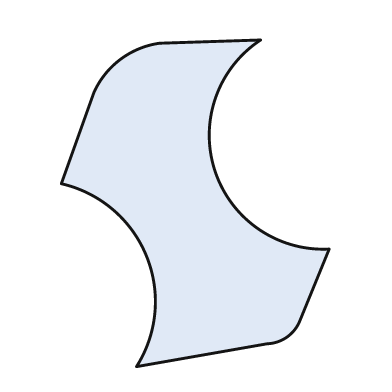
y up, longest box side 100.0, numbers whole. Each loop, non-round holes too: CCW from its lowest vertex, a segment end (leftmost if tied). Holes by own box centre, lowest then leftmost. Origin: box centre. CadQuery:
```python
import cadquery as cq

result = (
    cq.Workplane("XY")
    .moveTo(-18.0, -50.0)
    .lineTo(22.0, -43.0)
    .threePointArc((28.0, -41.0), (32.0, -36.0))
    .lineTo(41.0, -14.0)
    .threePointArc((6.0, 10.0), (20.0, 50.0))
    .lineTo(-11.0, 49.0)
    .threePointArc((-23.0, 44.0), (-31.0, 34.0))
    .lineTo(-41.0, 6.0)
    .threePointArc((-15.0, -16.0), (-18.0, -50.0))
    .close()
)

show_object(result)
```